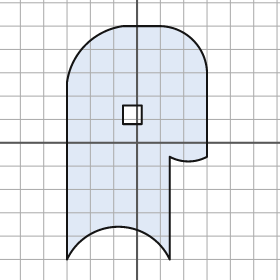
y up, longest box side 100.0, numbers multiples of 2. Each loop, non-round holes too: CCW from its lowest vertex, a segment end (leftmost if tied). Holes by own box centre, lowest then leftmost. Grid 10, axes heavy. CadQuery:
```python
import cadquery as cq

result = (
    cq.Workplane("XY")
    .moveTo(-30.0, -50.0)
    .threePointArc((-8.0, -36.0), (14.0, -50.0))
    .lineTo(14.0, -6.0)
    .threePointArc((22.0, -8.0), (30.0, -6.0))
    .lineTo(30.0, 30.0)
    .threePointArc((24.0, 44.0), (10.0, 50.0))
    .lineTo(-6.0, 50.0)
    .threePointArc((-22.0, 42.0), (-30.0, 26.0))
    .close()
    .moveTo(-6.0, 8.0)
    .lineTo(2.0, 8.0)
    .lineTo(2.0, 16.0)
    .lineTo(-6.0, 16.0)
    .close()
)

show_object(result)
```